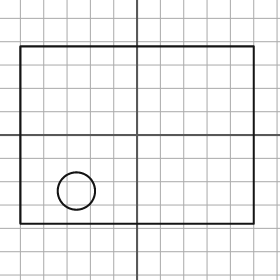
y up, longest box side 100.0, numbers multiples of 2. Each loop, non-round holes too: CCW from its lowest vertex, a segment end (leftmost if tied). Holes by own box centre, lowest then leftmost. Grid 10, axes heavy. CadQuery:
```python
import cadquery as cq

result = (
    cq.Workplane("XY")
    .moveTo(-50.0, -38.0)
    .lineTo(50.0, -38.0)
    .lineTo(50.0, 38.0)
    .lineTo(-50.0, 38.0)
    .close()
    .moveTo(-26.0, -24.0)
    .circle(8.0)
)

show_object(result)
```